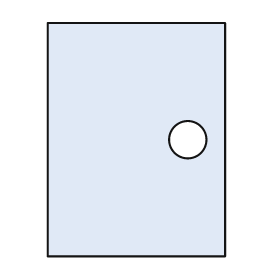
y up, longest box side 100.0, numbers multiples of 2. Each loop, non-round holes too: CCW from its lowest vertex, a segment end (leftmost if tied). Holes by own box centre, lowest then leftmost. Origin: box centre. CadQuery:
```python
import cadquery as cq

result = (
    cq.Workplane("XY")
    .moveTo(-38.0, -50.0)
    .lineTo(38.0, -50.0)
    .lineTo(38.0, 50.0)
    .lineTo(-38.0, 50.0)
    .close()
    .moveTo(22.0, 0.0)
    .circle(8.0)
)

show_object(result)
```